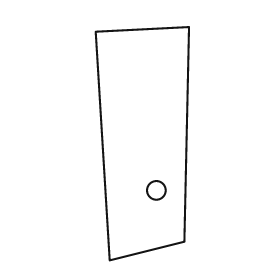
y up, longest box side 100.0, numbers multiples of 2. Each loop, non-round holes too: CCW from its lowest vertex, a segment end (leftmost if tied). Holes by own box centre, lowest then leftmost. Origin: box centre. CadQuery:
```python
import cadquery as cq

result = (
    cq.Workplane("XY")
    .moveTo(-14.0, -50.0)
    .lineTo(18.0, -42.0)
    .lineTo(20.0, 50.0)
    .lineTo(-20.0, 48.0)
    .close()
    .moveTo(6.0, -20.0)
    .circle(4.0)
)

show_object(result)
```